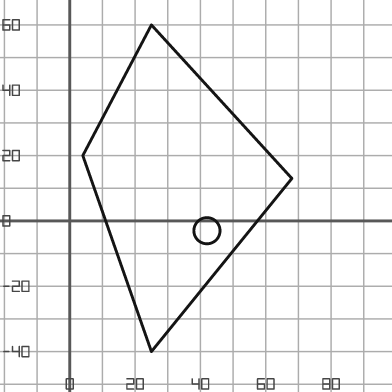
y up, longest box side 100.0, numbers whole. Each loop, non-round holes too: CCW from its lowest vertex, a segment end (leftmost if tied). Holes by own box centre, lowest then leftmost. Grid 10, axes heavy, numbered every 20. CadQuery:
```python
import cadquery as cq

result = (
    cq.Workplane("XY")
    .moveTo(25.0, -40.0)
    .lineTo(68.0, 13.0)
    .lineTo(25.0, 60.0)
    .lineTo(4.0, 20.0)
    .close()
    .moveTo(42.0, -3.0)
    .circle(4.0)
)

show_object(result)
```